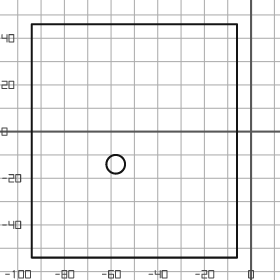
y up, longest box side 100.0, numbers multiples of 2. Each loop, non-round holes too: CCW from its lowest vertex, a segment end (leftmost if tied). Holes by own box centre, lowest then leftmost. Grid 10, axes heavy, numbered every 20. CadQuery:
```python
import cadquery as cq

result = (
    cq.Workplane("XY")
    .moveTo(-94.0, -54.0)
    .lineTo(-6.0, -54.0)
    .lineTo(-6.0, 46.0)
    .lineTo(-94.0, 46.0)
    .close()
    .moveTo(-58.0, -14.0)
    .circle(4.0)
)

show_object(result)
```